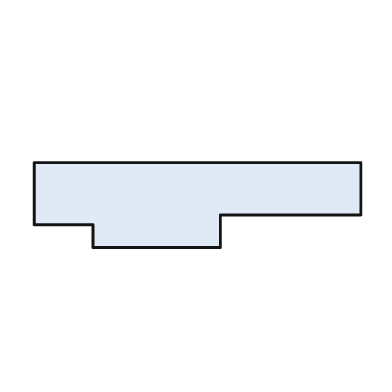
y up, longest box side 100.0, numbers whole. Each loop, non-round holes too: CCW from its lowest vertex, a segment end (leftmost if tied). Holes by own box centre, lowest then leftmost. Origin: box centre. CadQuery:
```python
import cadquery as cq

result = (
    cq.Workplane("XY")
    .moveTo(-32.0, -13.0)
    .lineTo(7.0, -13.0)
    .lineTo(7.0, -3.0)
    .lineTo(50.0, -3.0)
    .lineTo(50.0, 13.0)
    .lineTo(-50.0, 13.0)
    .lineTo(-50.0, -6.0)
    .lineTo(-32.0, -6.0)
    .close()
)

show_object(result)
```